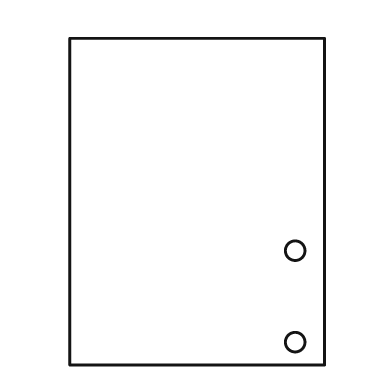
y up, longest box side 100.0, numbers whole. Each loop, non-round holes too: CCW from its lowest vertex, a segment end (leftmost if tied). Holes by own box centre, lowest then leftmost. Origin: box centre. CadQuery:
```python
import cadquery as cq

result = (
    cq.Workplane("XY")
    .moveTo(-39.0, -50.0)
    .lineTo(39.0, -50.0)
    .lineTo(39.0, 50.0)
    .lineTo(-39.0, 50.0)
    .close()
    .moveTo(30.0, -43.0)
    .circle(3.0)
    .moveTo(30.0, -15.0)
    .circle(3.0)
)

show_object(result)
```